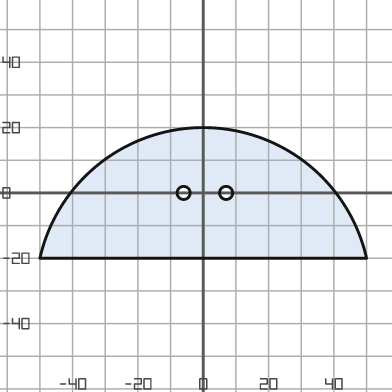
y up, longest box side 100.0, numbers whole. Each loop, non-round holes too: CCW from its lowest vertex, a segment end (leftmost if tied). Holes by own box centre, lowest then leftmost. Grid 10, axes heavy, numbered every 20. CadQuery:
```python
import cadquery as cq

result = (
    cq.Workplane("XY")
    .moveTo(-50.0, -20.0)
    .lineTo(50.0, -20.0)
    .threePointArc((0.0, 20.0), (-50.0, -20.0))
    .close()
    .moveTo(-6.0, 0.0)
    .circle(2.0)
    .moveTo(7.0, 0.0)
    .circle(2.0)
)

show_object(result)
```